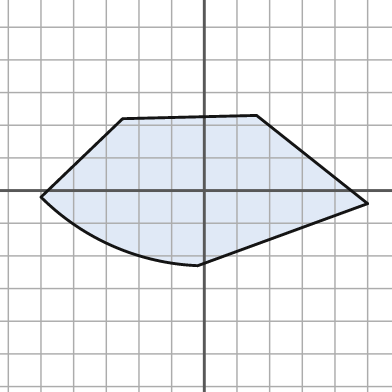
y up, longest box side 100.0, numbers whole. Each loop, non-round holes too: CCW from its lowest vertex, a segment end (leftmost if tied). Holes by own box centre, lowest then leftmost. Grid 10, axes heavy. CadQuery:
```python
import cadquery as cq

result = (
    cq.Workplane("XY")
    .moveTo(-2.0, -23.0)
    .lineTo(50.0, -4.0)
    .lineTo(16.0, 23.0)
    .lineTo(-25.0, 22.0)
    .lineTo(-50.0, -2.0)
    .threePointArc((-28.0, -17.0), (-2.0, -23.0))
    .close()
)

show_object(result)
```